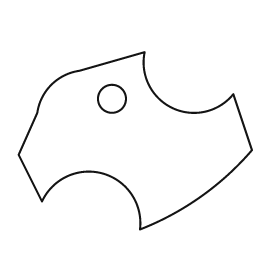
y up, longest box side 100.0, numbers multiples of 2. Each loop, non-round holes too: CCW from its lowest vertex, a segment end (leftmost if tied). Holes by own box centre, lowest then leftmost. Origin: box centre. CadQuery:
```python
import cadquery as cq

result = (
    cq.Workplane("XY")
    .moveTo(2.0, -38.0)
    .threePointArc((28.0, -24.0), (50.0, -4.0))
    .lineTo(42.0, 20.0)
    .threePointArc((16.0, 14.0), (4.0, 38.0))
    .lineTo(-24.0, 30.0)
    .threePointArc((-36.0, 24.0), (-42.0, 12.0))
    .lineTo(-50.0, -6.0)
    .lineTo(-40.0, -26.0)
    .threePointArc((-14.0, -14.0), (2.0, -38.0))
    .close()
    .moveTo(-10.0, 18.0)
    .circle(6.0)
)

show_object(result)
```